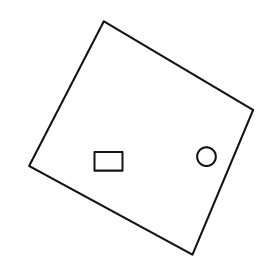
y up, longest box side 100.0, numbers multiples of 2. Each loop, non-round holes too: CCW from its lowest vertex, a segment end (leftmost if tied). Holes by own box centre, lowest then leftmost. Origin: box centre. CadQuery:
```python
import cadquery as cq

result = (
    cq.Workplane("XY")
    .moveTo(22.0, -50.0)
    .lineTo(48.0, 12.0)
    .lineTo(-16.0, 50.0)
    .lineTo(-48.0, -12.0)
    .close()
    .moveTo(-20.0, -14.0)
    .lineTo(-8.0, -14.0)
    .lineTo(-8.0, -6.0)
    .lineTo(-20.0, -6.0)
    .close()
    .moveTo(28.0, -8.0)
    .circle(4.0)
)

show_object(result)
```